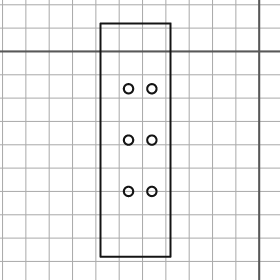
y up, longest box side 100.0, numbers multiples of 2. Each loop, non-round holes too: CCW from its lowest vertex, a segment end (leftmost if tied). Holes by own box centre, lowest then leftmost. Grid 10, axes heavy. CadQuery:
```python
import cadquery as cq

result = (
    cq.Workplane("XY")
    .moveTo(-68.0, -88.0)
    .lineTo(-38.0, -88.0)
    .lineTo(-38.0, 12.0)
    .lineTo(-68.0, 12.0)
    .close()
    .moveTo(-56.0, -60.0)
    .circle(2.0)
    .moveTo(-46.0, -60.0)
    .circle(2.0)
    .moveTo(-56.0, -38.0)
    .circle(2.0)
    .moveTo(-46.0, -38.0)
    .circle(2.0)
    .moveTo(-56.0, -16.0)
    .circle(2.0)
    .moveTo(-46.0, -16.0)
    .circle(2.0)
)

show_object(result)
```